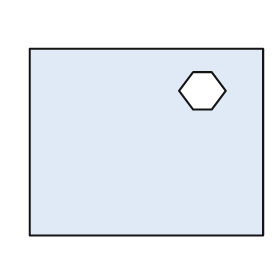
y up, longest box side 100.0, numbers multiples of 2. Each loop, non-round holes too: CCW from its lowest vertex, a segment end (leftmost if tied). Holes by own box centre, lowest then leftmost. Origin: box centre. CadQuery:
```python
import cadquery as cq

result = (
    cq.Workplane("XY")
    .moveTo(-50.0, -40.0)
    .lineTo(50.0, -40.0)
    .lineTo(50.0, 40.0)
    .lineTo(-50.0, 40.0)
    .close()
    .moveTo(20.0, 14.0)
    .lineTo(28.0, 14.0)
    .lineTo(34.0, 22.0)
    .lineTo(28.0, 30.0)
    .lineTo(20.0, 30.0)
    .lineTo(14.0, 22.0)
    .close()
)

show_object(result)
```